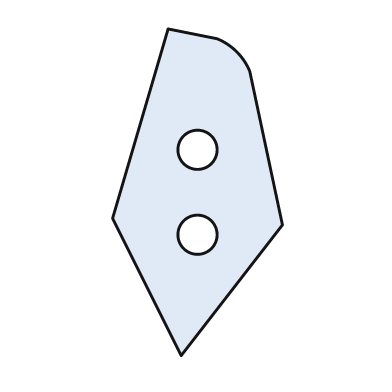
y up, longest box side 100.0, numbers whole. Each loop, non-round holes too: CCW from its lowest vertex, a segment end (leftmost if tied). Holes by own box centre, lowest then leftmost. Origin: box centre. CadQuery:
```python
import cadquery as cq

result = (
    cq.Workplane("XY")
    .moveTo(-5.0, -50.0)
    .lineTo(26.0, -10.0)
    .lineTo(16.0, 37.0)
    .threePointArc((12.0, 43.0), (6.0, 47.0))
    .lineTo(-9.0, 50.0)
    .lineTo(-26.0, -8.0)
    .close()
    .moveTo(0.0, -13.0)
    .circle(6.0)
    .moveTo(0.0, 13.0)
    .circle(6.0)
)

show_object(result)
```